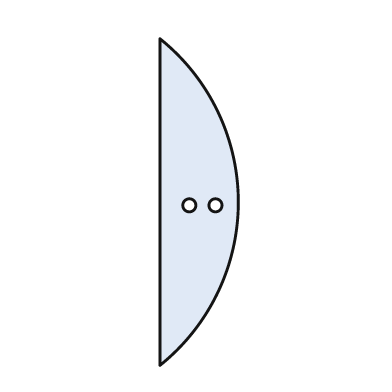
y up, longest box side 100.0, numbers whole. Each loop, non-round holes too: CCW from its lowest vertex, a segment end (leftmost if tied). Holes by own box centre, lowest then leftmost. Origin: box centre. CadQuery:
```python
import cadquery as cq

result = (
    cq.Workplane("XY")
    .moveTo(-12.0, -50.0)
    .threePointArc((12.0, 0.0), (-12.0, 50.0))
    .close()
    .moveTo(-3.0, -1.0)
    .circle(2.0)
    .moveTo(5.0, -1.0)
    .circle(2.0)
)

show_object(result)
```